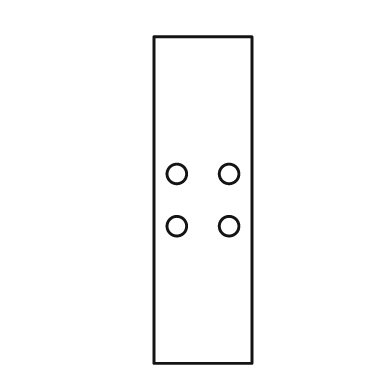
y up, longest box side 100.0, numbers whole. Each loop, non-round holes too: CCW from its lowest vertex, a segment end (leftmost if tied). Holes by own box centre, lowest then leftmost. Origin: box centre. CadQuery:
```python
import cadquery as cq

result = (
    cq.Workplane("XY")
    .moveTo(-15.0, -50.0)
    .lineTo(15.0, -50.0)
    .lineTo(15.0, 50.0)
    .lineTo(-15.0, 50.0)
    .close()
    .moveTo(-8.0, -8.0)
    .circle(3.0)
    .moveTo(8.0, -8.0)
    .circle(3.0)
    .moveTo(-8.0, 8.0)
    .circle(3.0)
    .moveTo(8.0, 8.0)
    .circle(3.0)
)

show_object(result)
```